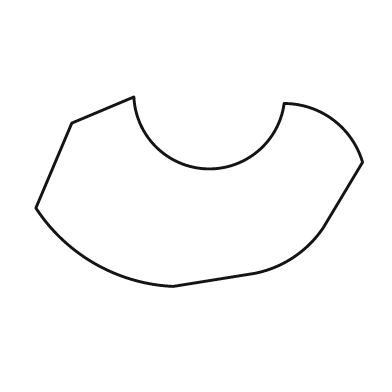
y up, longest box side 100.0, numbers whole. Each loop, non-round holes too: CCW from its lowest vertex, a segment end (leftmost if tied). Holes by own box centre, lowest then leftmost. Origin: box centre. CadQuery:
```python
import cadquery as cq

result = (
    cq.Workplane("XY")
    .moveTo(-8.0, -29.0)
    .lineTo(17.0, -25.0)
    .threePointArc((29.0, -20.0), (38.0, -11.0))
    .lineTo(50.0, 9.0)
    .threePointArc((41.0, 22.0), (26.0, 27.0))
    .threePointArc((2.0, 7.0), (-20.0, 29.0))
    .lineTo(-39.0, 21.0)
    .lineTo(-50.0, -5.0)
    .threePointArc((-32.0, -22.0), (-8.0, -29.0))
    .close()
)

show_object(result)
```